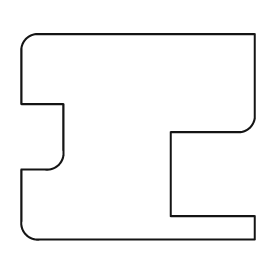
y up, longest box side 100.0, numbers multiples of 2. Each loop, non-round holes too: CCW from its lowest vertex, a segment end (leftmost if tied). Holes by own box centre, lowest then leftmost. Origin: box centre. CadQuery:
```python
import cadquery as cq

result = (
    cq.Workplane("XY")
    .moveTo(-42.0, -44.0)
    .lineTo(50.0, -44.0)
    .lineTo(50.0, -34.0)
    .lineTo(14.0, -34.0)
    .lineTo(14.0, 2.0)
    .lineTo(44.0, 2.0)
    .threePointArc((48.0, 4.0), (50.0, 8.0))
    .lineTo(50.0, 44.0)
    .lineTo(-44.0, 44.0)
    .threePointArc((-48.0, 42.0), (-50.0, 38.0))
    .lineTo(-50.0, 14.0)
    .lineTo(-32.0, 14.0)
    .lineTo(-32.0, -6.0)
    .threePointArc((-34.0, -12.0), (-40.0, -14.0))
    .lineTo(-50.0, -14.0)
    .lineTo(-50.0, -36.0)
    .threePointArc((-48.0, -42.0), (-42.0, -44.0))
    .close()
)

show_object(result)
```